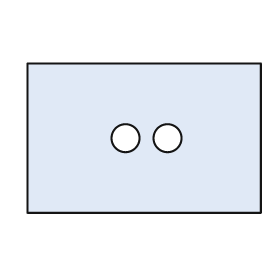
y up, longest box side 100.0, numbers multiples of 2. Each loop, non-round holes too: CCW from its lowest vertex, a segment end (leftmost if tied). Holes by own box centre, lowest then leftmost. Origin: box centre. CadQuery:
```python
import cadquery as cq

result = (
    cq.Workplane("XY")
    .moveTo(-50.0, -32.0)
    .lineTo(50.0, -32.0)
    .lineTo(50.0, 32.0)
    .lineTo(-50.0, 32.0)
    .close()
    .moveTo(-8.0, 0.0)
    .circle(6.0)
    .moveTo(10.0, 0.0)
    .circle(6.0)
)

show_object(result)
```